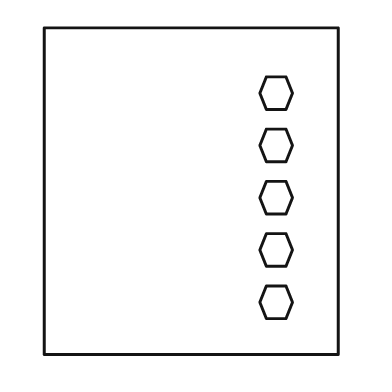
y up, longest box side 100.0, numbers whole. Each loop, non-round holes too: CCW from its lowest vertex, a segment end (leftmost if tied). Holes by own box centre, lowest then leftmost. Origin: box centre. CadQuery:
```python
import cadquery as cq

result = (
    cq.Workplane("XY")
    .moveTo(-45.0, -50.0)
    .lineTo(45.0, -50.0)
    .lineTo(45.0, 50.0)
    .lineTo(-45.0, 50.0)
    .close()
    .moveTo(23.0, -39.0)
    .lineTo(29.0, -39.0)
    .lineTo(31.0, -34.0)
    .lineTo(29.0, -29.0)
    .lineTo(23.0, -29.0)
    .lineTo(21.0, -34.0)
    .close()
    .moveTo(23.0, -23.0)
    .lineTo(29.0, -23.0)
    .lineTo(31.0, -18.0)
    .lineTo(29.0, -13.0)
    .lineTo(23.0, -13.0)
    .lineTo(21.0, -18.0)
    .close()
    .moveTo(23.0, -7.0)
    .lineTo(29.0, -7.0)
    .lineTo(31.0, -2.0)
    .lineTo(29.0, 3.0)
    .lineTo(23.0, 3.0)
    .lineTo(21.0, -2.0)
    .close()
    .moveTo(23.0, 9.0)
    .lineTo(29.0, 9.0)
    .lineTo(31.0, 14.0)
    .lineTo(29.0, 19.0)
    .lineTo(23.0, 19.0)
    .lineTo(21.0, 14.0)
    .close()
    .moveTo(23.0, 25.0)
    .lineTo(29.0, 25.0)
    .lineTo(31.0, 30.0)
    .lineTo(29.0, 35.0)
    .lineTo(23.0, 35.0)
    .lineTo(21.0, 30.0)
    .close()
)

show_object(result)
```